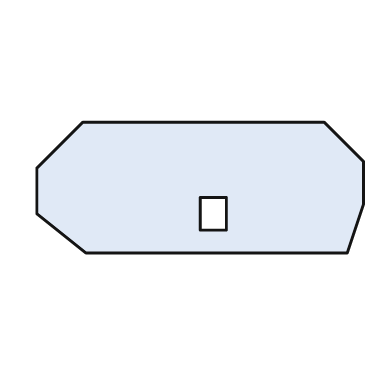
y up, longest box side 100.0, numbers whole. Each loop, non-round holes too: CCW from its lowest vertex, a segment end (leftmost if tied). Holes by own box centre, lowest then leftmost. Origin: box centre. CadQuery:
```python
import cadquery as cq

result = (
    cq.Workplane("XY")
    .moveTo(-35.0, -20.0)
    .lineTo(45.0, -20.0)
    .lineTo(50.0, -5.0)
    .lineTo(50.0, 8.0)
    .lineTo(38.0, 20.0)
    .lineTo(-36.0, 20.0)
    .lineTo(-50.0, 6.0)
    .lineTo(-50.0, -8.0)
    .close()
    .moveTo(0.0, -13.0)
    .lineTo(8.0, -13.0)
    .lineTo(8.0, -3.0)
    .lineTo(0.0, -3.0)
    .close()
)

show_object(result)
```